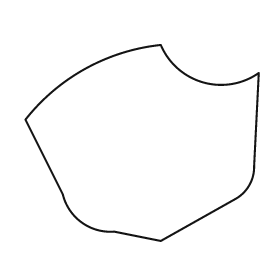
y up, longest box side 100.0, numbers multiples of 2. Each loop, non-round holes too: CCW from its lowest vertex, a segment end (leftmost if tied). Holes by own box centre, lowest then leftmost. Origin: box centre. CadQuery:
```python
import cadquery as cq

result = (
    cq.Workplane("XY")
    .moveTo(8.0, -42.0)
    .lineTo(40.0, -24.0)
    .threePointArc((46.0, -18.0), (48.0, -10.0))
    .lineTo(50.0, 30.0)
    .threePointArc((26.0, 26.0), (8.0, 42.0))
    .threePointArc((-24.0, 32.0), (-50.0, 10.0))
    .lineTo(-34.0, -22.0)
    .threePointArc((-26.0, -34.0), (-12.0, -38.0))
    .close()
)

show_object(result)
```